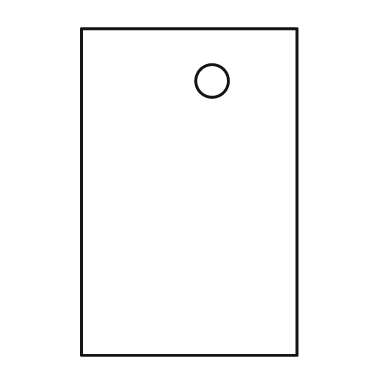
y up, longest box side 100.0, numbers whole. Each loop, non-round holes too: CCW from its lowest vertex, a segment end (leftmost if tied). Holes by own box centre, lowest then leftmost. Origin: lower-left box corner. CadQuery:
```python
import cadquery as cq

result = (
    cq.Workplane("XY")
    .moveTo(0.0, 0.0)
    .lineTo(66.0, 0.0)
    .lineTo(66.0, 100.0)
    .lineTo(0.0, 100.0)
    .close()
    .moveTo(40.0, 84.0)
    .circle(5.0)
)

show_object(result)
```